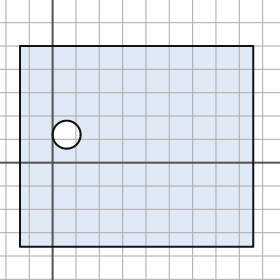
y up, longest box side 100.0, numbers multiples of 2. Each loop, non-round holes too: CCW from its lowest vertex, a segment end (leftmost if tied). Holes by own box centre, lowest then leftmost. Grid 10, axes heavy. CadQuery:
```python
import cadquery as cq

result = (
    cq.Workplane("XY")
    .moveTo(-14.0, -36.0)
    .lineTo(86.0, -36.0)
    .lineTo(86.0, 50.0)
    .lineTo(-14.0, 50.0)
    .close()
    .moveTo(6.0, 12.0)
    .circle(6.0)
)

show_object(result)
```